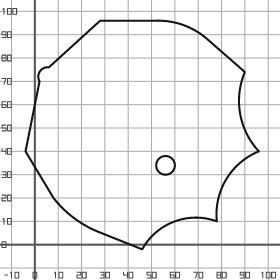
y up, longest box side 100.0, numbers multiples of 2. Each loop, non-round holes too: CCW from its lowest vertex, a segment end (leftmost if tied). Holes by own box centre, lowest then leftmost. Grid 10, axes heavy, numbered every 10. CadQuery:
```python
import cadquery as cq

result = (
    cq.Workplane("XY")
    .moveTo(46.0, -2.0)
    .threePointArc((60.0, 10.0), (78.0, 10.0))
    .threePointArc((82.0, 28.0), (96.0, 40.0))
    .threePointArc((88.0, 56.0), (90.0, 74.0))
    .lineTo(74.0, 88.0)
    .threePointArc((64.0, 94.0), (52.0, 96.0))
    .lineTo(28.0, 96.0)
    .lineTo(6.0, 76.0)
    .threePointArc((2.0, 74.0), (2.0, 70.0))
    .lineTo(-4.0, 40.0)
    .lineTo(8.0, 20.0)
    .threePointArc((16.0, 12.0), (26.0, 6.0))
    .close()
    .moveTo(56.0, 34.0)
    .circle(4.0)
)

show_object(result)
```